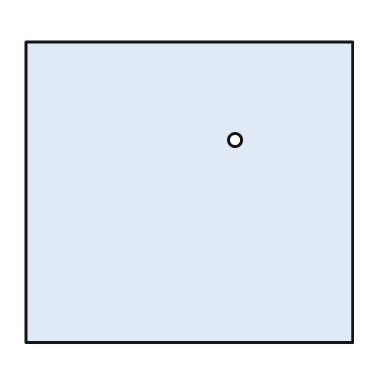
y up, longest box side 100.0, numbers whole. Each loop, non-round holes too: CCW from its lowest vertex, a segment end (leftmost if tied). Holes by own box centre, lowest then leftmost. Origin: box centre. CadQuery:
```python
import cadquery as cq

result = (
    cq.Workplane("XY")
    .moveTo(-50.0, -46.0)
    .lineTo(50.0, -46.0)
    .lineTo(50.0, 46.0)
    .lineTo(-50.0, 46.0)
    .close()
    .moveTo(14.0, 16.0)
    .circle(2.0)
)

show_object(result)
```